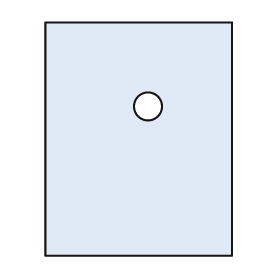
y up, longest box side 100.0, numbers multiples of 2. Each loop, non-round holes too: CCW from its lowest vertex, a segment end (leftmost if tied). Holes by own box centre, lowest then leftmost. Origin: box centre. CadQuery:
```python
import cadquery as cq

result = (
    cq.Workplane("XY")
    .moveTo(-40.0, -50.0)
    .lineTo(40.0, -50.0)
    .lineTo(40.0, 50.0)
    .lineTo(-40.0, 50.0)
    .close()
    .moveTo(4.0, 14.0)
    .circle(6.0)
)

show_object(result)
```